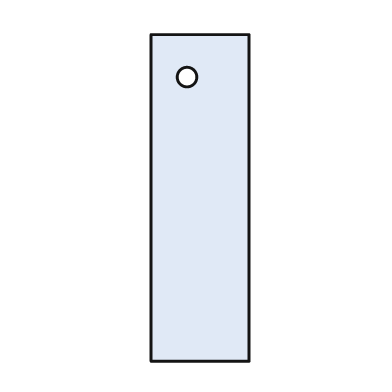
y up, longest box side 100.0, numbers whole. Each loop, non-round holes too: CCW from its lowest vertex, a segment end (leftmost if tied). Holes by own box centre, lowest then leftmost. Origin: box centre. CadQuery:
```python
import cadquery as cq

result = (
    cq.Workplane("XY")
    .moveTo(-15.0, -50.0)
    .lineTo(15.0, -50.0)
    .lineTo(15.0, 50.0)
    .lineTo(-15.0, 50.0)
    .close()
    .moveTo(-4.0, 37.0)
    .circle(3.0)
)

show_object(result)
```